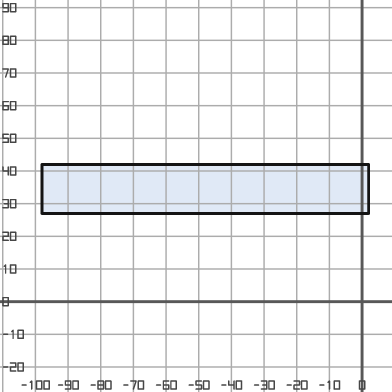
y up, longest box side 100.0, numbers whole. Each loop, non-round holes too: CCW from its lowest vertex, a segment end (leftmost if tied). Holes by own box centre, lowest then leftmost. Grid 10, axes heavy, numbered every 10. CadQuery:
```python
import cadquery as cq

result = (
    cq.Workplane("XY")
    .moveTo(-98.0, 27.0)
    .lineTo(2.0, 27.0)
    .lineTo(2.0, 42.0)
    .lineTo(-98.0, 42.0)
    .close()
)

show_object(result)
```